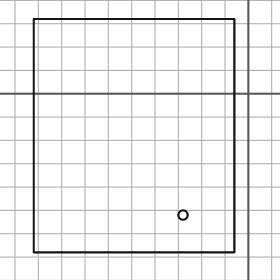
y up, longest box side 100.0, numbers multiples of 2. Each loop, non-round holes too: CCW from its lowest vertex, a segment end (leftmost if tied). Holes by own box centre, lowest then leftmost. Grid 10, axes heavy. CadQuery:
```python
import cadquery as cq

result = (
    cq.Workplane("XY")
    .moveTo(-92.0, -68.0)
    .lineTo(-6.0, -68.0)
    .lineTo(-6.0, 32.0)
    .lineTo(-92.0, 32.0)
    .close()
    .moveTo(-28.0, -52.0)
    .circle(2.0)
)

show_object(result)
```